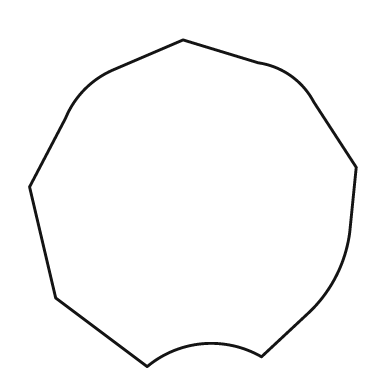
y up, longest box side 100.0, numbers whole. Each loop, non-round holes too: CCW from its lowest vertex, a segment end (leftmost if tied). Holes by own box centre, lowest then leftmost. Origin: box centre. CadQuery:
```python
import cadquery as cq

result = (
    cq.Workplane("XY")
    .moveTo(-14.0, -50.0)
    .threePointArc((3.0, -43.0), (21.0, -47.0))
    .lineTo(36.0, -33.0)
    .threePointArc((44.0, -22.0), (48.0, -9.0))
    .lineTo(50.0, 11.0)
    .lineTo(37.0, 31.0)
    .threePointArc((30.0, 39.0), (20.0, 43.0))
    .lineTo(-3.0, 50.0)
    .lineTo(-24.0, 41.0)
    .threePointArc((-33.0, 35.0), (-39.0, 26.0))
    .lineTo(-50.0, 5.0)
    .lineTo(-42.0, -29.0)
    .close()
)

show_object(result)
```